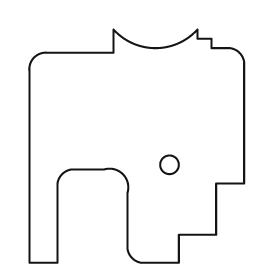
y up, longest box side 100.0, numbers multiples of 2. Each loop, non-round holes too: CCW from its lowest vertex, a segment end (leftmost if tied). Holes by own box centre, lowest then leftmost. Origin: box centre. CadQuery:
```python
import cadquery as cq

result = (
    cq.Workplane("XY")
    .moveTo(-46.0, -50.0)
    .lineTo(-34.0, -50.0)
    .lineTo(-34.0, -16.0)
    .threePointArc((-32.0, -12.0), (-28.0, -10.0))
    .lineTo(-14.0, -10.0)
    .threePointArc((-6.0, -12.0), (-4.0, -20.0))
    .lineTo(-4.0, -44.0)
    .threePointArc((-2.0, -48.0), (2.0, -50.0))
    .lineTo(18.0, -50.0)
    .lineTo(18.0, -38.0)
    .lineTo(34.0, -38.0)
    .lineTo(34.0, -16.0)
    .lineTo(46.0, -16.0)
    .lineTo(46.0, 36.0)
    .threePointArc((44.0, 40.0), (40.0, 42.0))
    .lineTo(32.0, 42.0)
    .lineTo(32.0, 46.0)
    .lineTo(26.0, 46.0)
    .lineTo(26.0, 50.0)
    .threePointArc((8.0, 42.0), (-10.0, 50.0))
    .lineTo(-10.0, 40.0)
    .lineTo(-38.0, 40.0)
    .threePointArc((-44.0, 38.0), (-46.0, 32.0))
    .close()
    .moveTo(14.0, -8.0)
    .circle(4.0)
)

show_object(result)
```